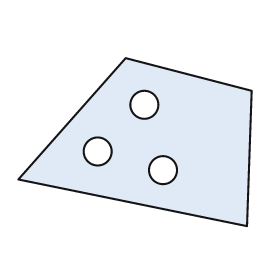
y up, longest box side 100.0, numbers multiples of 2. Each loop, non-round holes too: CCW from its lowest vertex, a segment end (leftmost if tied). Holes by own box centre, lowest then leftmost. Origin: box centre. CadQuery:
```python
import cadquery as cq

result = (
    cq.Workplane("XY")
    .moveTo(48.0, -36.0)
    .lineTo(50.0, 22.0)
    .lineTo(-4.0, 36.0)
    .lineTo(-50.0, -16.0)
    .close()
    .moveTo(12.0, -12.0)
    .circle(6.0)
    .moveTo(-16.0, -4.0)
    .circle(6.0)
    .moveTo(4.0, 16.0)
    .circle(6.0)
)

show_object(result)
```